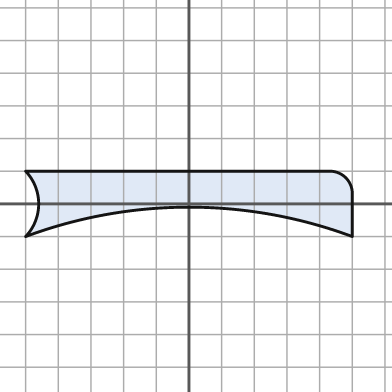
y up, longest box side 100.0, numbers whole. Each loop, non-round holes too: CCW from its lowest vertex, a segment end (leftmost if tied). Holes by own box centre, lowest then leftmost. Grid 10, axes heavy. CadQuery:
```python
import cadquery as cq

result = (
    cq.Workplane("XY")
    .moveTo(-50.0, -10.0)
    .threePointArc((0.0, -1.0), (50.0, -10.0))
    .lineTo(50.0, 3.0)
    .threePointArc((48.0, 8.0), (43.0, 10.0))
    .lineTo(-50.0, 10.0)
    .threePointArc((-46.0, 0.0), (-50.0, -10.0))
    .close()
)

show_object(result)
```